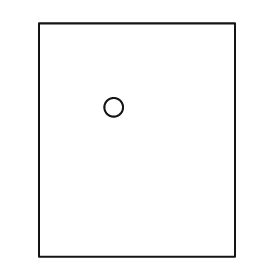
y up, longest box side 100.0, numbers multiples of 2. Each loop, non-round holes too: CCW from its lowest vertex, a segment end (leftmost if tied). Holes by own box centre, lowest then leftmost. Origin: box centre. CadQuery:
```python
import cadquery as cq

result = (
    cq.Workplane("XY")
    .moveTo(-42.0, -50.0)
    .lineTo(42.0, -50.0)
    .lineTo(42.0, 50.0)
    .lineTo(-42.0, 50.0)
    .close()
    .moveTo(-10.0, 14.0)
    .circle(4.0)
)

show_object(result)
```